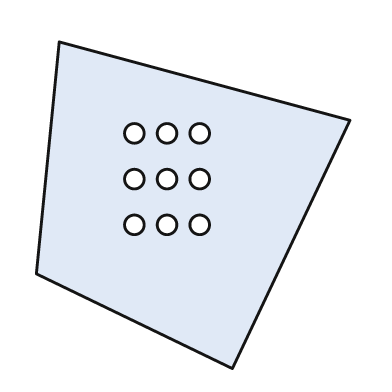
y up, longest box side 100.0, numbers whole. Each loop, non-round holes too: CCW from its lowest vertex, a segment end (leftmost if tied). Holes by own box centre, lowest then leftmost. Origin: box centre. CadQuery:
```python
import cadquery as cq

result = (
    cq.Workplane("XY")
    .moveTo(12.0, -50.0)
    .lineTo(48.0, 26.0)
    .lineTo(-41.0, 50.0)
    .lineTo(-48.0, -21.0)
    .close()
    .moveTo(-18.0, -6.0)
    .circle(3.0)
    .moveTo(-8.0, -6.0)
    .circle(3.0)
    .moveTo(2.0, -6.0)
    .circle(3.0)
    .moveTo(-18.0, 8.0)
    .circle(3.0)
    .moveTo(-8.0, 8.0)
    .circle(3.0)
    .moveTo(2.0, 8.0)
    .circle(3.0)
    .moveTo(-18.0, 22.0)
    .circle(3.0)
    .moveTo(-8.0, 22.0)
    .circle(3.0)
    .moveTo(2.0, 22.0)
    .circle(3.0)
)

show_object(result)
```